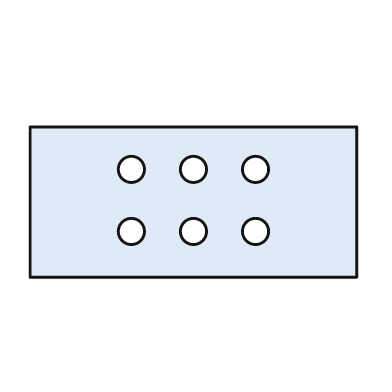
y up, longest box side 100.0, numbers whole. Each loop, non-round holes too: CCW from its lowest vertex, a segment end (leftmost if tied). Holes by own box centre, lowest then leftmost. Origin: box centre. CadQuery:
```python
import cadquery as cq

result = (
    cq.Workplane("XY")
    .moveTo(-50.0, -23.0)
    .lineTo(50.0, -23.0)
    .lineTo(50.0, 23.0)
    .lineTo(-50.0, 23.0)
    .close()
    .moveTo(-19.0, -9.0)
    .circle(4.0)
    .moveTo(0.0, -9.0)
    .circle(4.0)
    .moveTo(19.0, -9.0)
    .circle(4.0)
    .moveTo(-19.0, 10.0)
    .circle(4.0)
    .moveTo(0.0, 10.0)
    .circle(4.0)
    .moveTo(19.0, 10.0)
    .circle(4.0)
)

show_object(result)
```